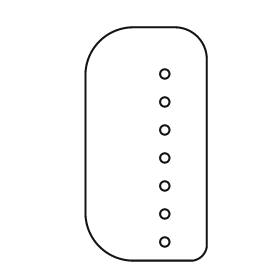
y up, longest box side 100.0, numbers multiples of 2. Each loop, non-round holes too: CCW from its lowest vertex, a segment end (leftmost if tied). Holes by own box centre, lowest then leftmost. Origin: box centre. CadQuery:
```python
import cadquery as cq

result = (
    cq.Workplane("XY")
    .moveTo(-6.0, -50.0)
    .lineTo(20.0, -50.0)
    .threePointArc((24.0, -48.0), (26.0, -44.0))
    .lineTo(26.0, 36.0)
    .threePointArc((22.0, 46.0), (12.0, 50.0))
    .lineTo(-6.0, 50.0)
    .threePointArc((-20.0, 44.0), (-26.0, 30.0))
    .lineTo(-26.0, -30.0)
    .threePointArc((-20.0, -44.0), (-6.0, -50.0))
    .close()
    .moveTo(8.0, -42.0)
    .circle(2.0)
    .moveTo(8.0, -30.0)
    .circle(2.0)
    .moveTo(8.0, -18.0)
    .circle(2.0)
    .moveTo(8.0, -6.0)
    .circle(2.0)
    .moveTo(8.0, 6.0)
    .circle(2.0)
    .moveTo(8.0, 18.0)
    .circle(2.0)
    .moveTo(8.0, 30.0)
    .circle(2.0)
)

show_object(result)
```